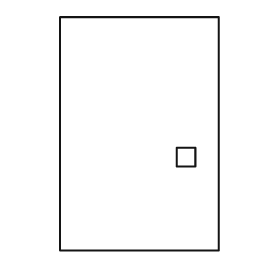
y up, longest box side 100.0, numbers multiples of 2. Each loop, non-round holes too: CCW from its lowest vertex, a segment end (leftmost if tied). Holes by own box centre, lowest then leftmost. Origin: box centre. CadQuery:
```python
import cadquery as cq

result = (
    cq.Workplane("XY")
    .moveTo(-34.0, -50.0)
    .lineTo(34.0, -50.0)
    .lineTo(34.0, 50.0)
    .lineTo(-34.0, 50.0)
    .close()
    .moveTo(16.0, -14.0)
    .lineTo(24.0, -14.0)
    .lineTo(24.0, -6.0)
    .lineTo(16.0, -6.0)
    .close()
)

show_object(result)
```